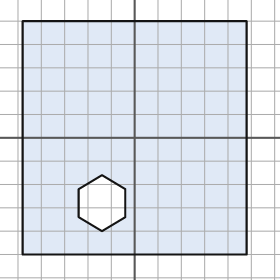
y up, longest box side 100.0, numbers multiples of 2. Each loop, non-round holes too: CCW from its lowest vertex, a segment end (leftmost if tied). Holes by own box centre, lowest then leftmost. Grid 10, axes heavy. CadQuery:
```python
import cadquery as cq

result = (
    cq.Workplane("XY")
    .moveTo(-48.0, -50.0)
    .lineTo(48.0, -50.0)
    .lineTo(48.0, 50.0)
    .lineTo(-48.0, 50.0)
    .close()
    .moveTo(-14.0, -40.0)
    .lineTo(-4.0, -34.0)
    .lineTo(-4.0, -22.0)
    .lineTo(-14.0, -16.0)
    .lineTo(-24.0, -22.0)
    .lineTo(-24.0, -34.0)
    .close()
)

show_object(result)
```